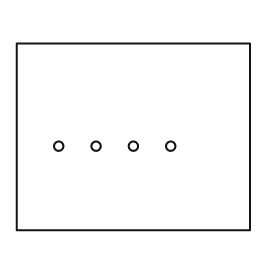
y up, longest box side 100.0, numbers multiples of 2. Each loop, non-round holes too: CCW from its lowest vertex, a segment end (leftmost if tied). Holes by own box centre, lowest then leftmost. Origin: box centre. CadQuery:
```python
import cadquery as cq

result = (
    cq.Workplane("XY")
    .moveTo(-50.0, -40.0)
    .lineTo(50.0, -40.0)
    .lineTo(50.0, 40.0)
    .lineTo(-50.0, 40.0)
    .close()
    .moveTo(-32.0, -4.0)
    .circle(2.0)
    .moveTo(-16.0, -4.0)
    .circle(2.0)
    .moveTo(0.0, -4.0)
    .circle(2.0)
    .moveTo(16.0, -4.0)
    .circle(2.0)
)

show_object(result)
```